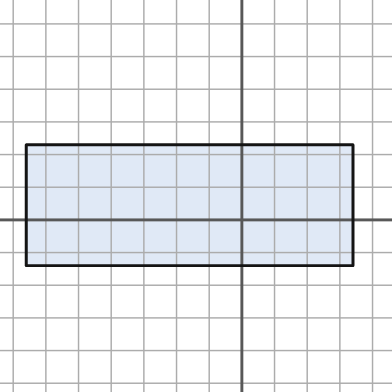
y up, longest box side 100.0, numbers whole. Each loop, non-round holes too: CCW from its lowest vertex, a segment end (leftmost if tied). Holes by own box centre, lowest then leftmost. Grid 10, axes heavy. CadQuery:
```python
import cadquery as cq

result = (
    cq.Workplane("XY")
    .moveTo(-66.0, -14.0)
    .lineTo(34.0, -14.0)
    .lineTo(34.0, 23.0)
    .lineTo(-66.0, 23.0)
    .close()
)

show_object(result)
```